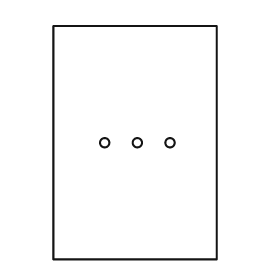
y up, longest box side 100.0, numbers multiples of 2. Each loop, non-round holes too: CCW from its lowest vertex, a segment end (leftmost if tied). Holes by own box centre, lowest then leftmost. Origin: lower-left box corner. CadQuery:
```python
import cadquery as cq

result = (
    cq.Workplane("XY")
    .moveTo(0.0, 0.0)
    .lineTo(70.0, 0.0)
    .lineTo(70.0, 100.0)
    .lineTo(0.0, 100.0)
    .close()
    .moveTo(22.0, 50.0)
    .circle(2.0)
    .moveTo(36.0, 50.0)
    .circle(2.0)
    .moveTo(50.0, 50.0)
    .circle(2.0)
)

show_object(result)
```